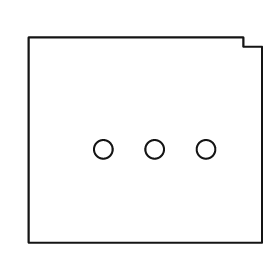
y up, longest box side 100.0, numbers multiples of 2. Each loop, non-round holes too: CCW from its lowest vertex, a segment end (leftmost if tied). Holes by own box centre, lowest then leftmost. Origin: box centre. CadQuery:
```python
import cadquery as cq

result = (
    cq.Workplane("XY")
    .moveTo(-50.0, -44.0)
    .lineTo(50.0, -44.0)
    .lineTo(50.0, 40.0)
    .lineTo(42.0, 40.0)
    .lineTo(42.0, 44.0)
    .lineTo(-50.0, 44.0)
    .close()
    .moveTo(-18.0, -4.0)
    .circle(4.0)
    .moveTo(4.0, -4.0)
    .circle(4.0)
    .moveTo(26.0, -4.0)
    .circle(4.0)
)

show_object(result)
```